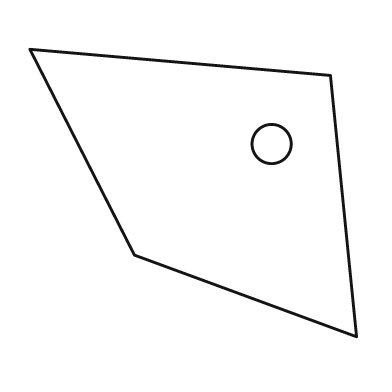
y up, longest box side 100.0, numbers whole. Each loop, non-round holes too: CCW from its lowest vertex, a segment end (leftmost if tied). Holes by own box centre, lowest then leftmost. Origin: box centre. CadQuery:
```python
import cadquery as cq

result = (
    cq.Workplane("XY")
    .moveTo(50.0, -44.0)
    .lineTo(42.0, 36.0)
    .lineTo(-50.0, 44.0)
    .lineTo(-18.0, -19.0)
    .close()
    .moveTo(24.0, 15.0)
    .circle(6.0)
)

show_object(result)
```